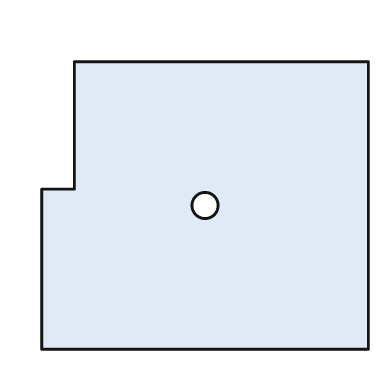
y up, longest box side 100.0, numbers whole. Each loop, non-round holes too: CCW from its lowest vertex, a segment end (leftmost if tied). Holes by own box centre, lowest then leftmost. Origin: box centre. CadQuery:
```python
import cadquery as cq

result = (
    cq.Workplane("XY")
    .moveTo(-50.0, -44.0)
    .lineTo(50.0, -44.0)
    .lineTo(50.0, 44.0)
    .lineTo(-40.0, 44.0)
    .lineTo(-40.0, 5.0)
    .lineTo(-50.0, 5.0)
    .close()
    .moveTo(0.0, 0.0)
    .circle(4.0)
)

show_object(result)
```